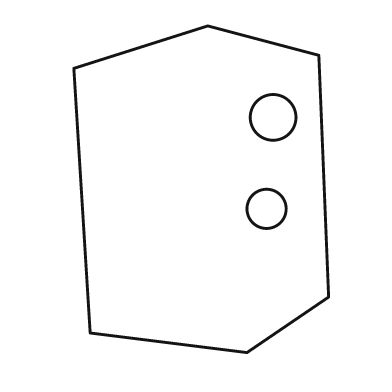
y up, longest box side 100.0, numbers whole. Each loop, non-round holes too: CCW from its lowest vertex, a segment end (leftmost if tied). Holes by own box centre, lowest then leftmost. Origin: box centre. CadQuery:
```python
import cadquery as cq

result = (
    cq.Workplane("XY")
    .moveTo(14.0, -50.0)
    .lineTo(39.0, -33.0)
    .lineTo(36.0, 41.0)
    .lineTo(2.0, 50.0)
    .lineTo(-39.0, 37.0)
    .lineTo(-34.0, -44.0)
    .close()
    .moveTo(20.0, -6.0)
    .circle(6.0)
    .moveTo(22.0, 22.0)
    .circle(7.0)
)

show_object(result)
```